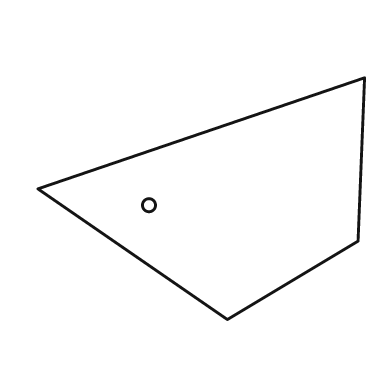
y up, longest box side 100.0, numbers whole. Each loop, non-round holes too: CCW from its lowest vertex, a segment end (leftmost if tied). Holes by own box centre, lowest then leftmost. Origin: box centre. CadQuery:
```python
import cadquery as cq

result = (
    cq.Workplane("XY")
    .moveTo(8.0, -37.0)
    .lineTo(48.0, -13.0)
    .lineTo(50.0, 37.0)
    .lineTo(-50.0, 3.0)
    .close()
    .moveTo(-16.0, -2.0)
    .circle(2.0)
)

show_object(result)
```